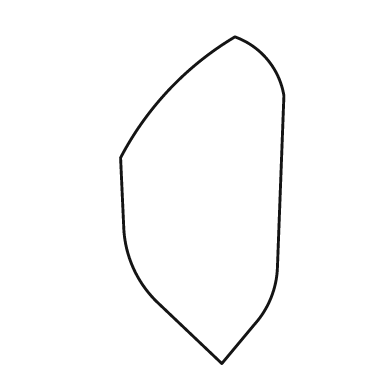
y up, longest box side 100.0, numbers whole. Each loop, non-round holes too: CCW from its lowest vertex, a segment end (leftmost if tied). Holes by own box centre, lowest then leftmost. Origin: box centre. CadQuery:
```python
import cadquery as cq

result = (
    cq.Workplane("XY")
    .moveTo(6.0, -50.0)
    .lineTo(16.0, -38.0)
    .threePointArc((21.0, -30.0), (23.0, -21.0))
    .lineTo(25.0, 32.0)
    .threePointArc((20.0, 43.0), (10.0, 50.0))
    .threePointArc((-10.0, 34.0), (-25.0, 13.0))
    .lineTo(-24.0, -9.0)
    .threePointArc((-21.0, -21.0), (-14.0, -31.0))
    .close()
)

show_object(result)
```